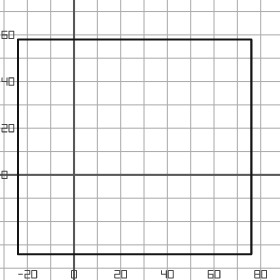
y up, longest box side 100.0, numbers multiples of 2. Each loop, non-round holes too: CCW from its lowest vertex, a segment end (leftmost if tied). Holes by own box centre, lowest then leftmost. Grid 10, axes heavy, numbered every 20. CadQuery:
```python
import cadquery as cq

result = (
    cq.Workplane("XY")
    .moveTo(-24.0, -34.0)
    .lineTo(76.0, -34.0)
    .lineTo(76.0, 58.0)
    .lineTo(-24.0, 58.0)
    .close()
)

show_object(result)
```